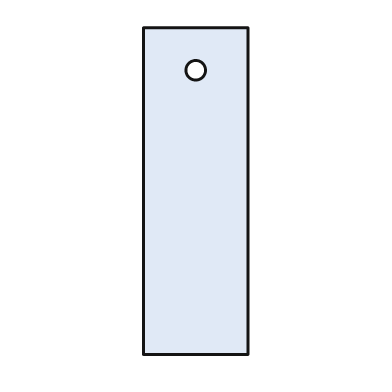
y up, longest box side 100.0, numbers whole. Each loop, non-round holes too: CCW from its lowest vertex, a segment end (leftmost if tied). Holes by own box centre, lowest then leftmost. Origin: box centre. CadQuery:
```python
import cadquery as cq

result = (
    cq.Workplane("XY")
    .moveTo(-16.0, -50.0)
    .lineTo(16.0, -50.0)
    .lineTo(16.0, 50.0)
    .lineTo(-16.0, 50.0)
    .close()
    .moveTo(0.0, 37.0)
    .circle(3.0)
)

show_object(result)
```